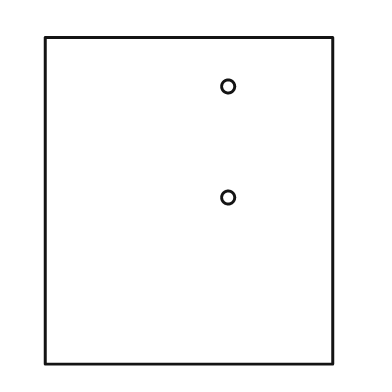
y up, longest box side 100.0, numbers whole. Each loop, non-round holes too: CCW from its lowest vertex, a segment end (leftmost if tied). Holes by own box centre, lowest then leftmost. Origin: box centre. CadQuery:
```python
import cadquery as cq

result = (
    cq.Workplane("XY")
    .moveTo(-44.0, -50.0)
    .lineTo(44.0, -50.0)
    .lineTo(44.0, 50.0)
    .lineTo(-44.0, 50.0)
    .close()
    .moveTo(12.0, 1.0)
    .circle(2.0)
    .moveTo(12.0, 35.0)
    .circle(2.0)
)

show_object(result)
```